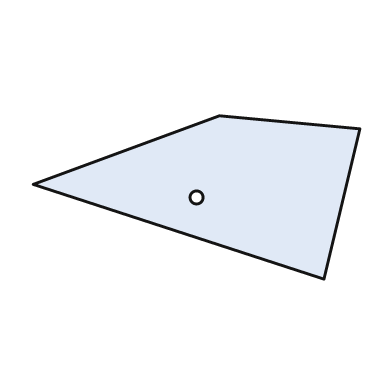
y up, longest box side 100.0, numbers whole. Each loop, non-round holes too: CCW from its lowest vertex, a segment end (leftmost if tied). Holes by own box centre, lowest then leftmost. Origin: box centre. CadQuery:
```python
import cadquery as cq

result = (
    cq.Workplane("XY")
    .moveTo(39.0, -25.0)
    .lineTo(50.0, 21.0)
    .lineTo(7.0, 25.0)
    .lineTo(-50.0, 4.0)
    .close()
    .moveTo(0.0, 0.0)
    .circle(2.0)
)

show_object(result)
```